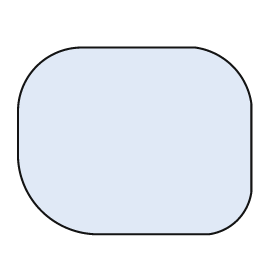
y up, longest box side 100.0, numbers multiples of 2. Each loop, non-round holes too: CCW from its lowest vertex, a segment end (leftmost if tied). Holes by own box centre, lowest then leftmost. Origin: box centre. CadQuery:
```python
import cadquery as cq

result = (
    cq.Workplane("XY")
    .moveTo(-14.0, -40.0)
    .lineTo(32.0, -40.0)
    .threePointArc((44.0, -34.0), (50.0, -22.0))
    .lineTo(50.0, 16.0)
    .threePointArc((42.0, 32.0), (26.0, 40.0))
    .lineTo(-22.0, 40.0)
    .threePointArc((-42.0, 32.0), (-50.0, 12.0))
    .lineTo(-50.0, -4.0)
    .threePointArc((-40.0, -30.0), (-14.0, -40.0))
    .close()
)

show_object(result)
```